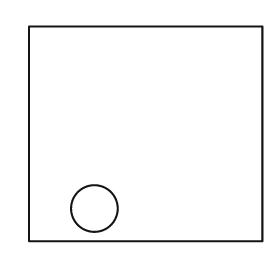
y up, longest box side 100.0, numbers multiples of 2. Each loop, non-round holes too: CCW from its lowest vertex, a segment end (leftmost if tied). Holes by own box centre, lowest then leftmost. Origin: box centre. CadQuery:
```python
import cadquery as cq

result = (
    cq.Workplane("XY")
    .moveTo(-50.0, -46.0)
    .lineTo(50.0, -46.0)
    .lineTo(50.0, 46.0)
    .lineTo(-50.0, 46.0)
    .close()
    .moveTo(-22.0, -32.0)
    .circle(10.0)
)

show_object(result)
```